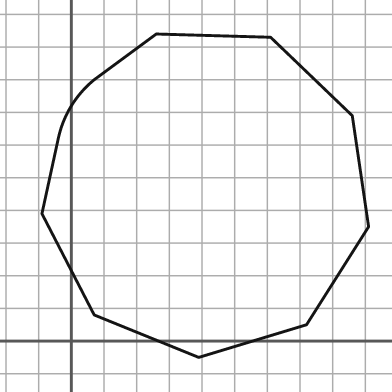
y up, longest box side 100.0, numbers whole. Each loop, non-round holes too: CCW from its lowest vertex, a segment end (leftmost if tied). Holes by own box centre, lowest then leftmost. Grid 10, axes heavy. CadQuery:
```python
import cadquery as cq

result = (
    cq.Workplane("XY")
    .moveTo(39.0, -5.0)
    .lineTo(72.0, 5.0)
    .lineTo(91.0, 35.0)
    .lineTo(86.0, 69.0)
    .lineTo(61.0, 93.0)
    .lineTo(26.0, 94.0)
    .lineTo(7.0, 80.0)
    .threePointArc((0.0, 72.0), (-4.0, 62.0))
    .lineTo(-9.0, 39.0)
    .lineTo(7.0, 8.0)
    .close()
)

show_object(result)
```